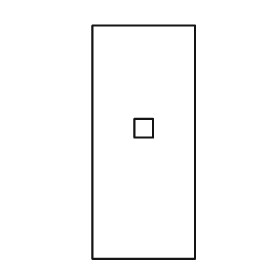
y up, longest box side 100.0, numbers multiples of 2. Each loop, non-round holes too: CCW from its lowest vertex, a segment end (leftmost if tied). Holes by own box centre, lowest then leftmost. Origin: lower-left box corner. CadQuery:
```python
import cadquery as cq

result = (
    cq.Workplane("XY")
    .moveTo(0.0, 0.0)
    .lineTo(44.0, 0.0)
    .lineTo(44.0, 100.0)
    .lineTo(0.0, 100.0)
    .close()
    .moveTo(18.0, 52.0)
    .lineTo(26.0, 52.0)
    .lineTo(26.0, 60.0)
    .lineTo(18.0, 60.0)
    .close()
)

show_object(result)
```